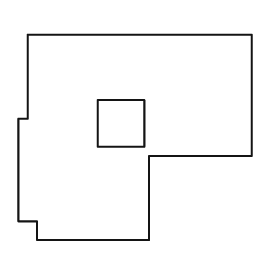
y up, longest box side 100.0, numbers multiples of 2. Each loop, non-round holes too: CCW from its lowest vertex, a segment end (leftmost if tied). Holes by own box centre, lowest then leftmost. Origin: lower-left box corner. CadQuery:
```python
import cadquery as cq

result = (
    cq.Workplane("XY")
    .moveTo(8.0, 0.0)
    .lineTo(56.0, 0.0)
    .lineTo(56.0, 36.0)
    .lineTo(100.0, 36.0)
    .lineTo(100.0, 88.0)
    .lineTo(4.0, 88.0)
    .lineTo(4.0, 52.0)
    .lineTo(0.0, 52.0)
    .lineTo(0.0, 8.0)
    .lineTo(8.0, 8.0)
    .close()
    .moveTo(34.0, 40.0)
    .lineTo(54.0, 40.0)
    .lineTo(54.0, 60.0)
    .lineTo(34.0, 60.0)
    .close()
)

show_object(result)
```